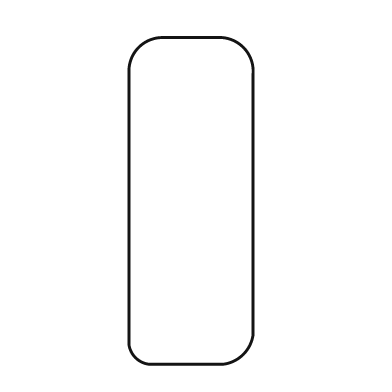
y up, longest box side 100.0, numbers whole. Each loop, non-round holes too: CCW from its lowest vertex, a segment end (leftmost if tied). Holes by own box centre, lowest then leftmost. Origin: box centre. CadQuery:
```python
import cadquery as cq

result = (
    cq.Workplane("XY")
    .moveTo(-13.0, -50.0)
    .lineTo(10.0, -50.0)
    .threePointArc((16.0, -47.0), (19.0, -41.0))
    .lineTo(19.0, 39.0)
    .threePointArc((16.0, 47.0), (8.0, 50.0))
    .lineTo(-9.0, 50.0)
    .threePointArc((-16.0, 47.0), (-19.0, 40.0))
    .lineTo(-19.0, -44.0)
    .threePointArc((-17.0, -48.0), (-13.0, -50.0))
    .close()
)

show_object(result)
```